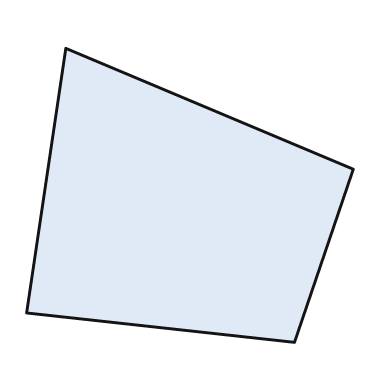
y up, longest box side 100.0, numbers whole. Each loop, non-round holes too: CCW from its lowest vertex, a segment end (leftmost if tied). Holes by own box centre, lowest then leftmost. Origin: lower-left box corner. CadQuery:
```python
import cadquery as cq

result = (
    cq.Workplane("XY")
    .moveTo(82.0, 0.0)
    .lineTo(100.0, 53.0)
    .lineTo(12.0, 90.0)
    .lineTo(0.0, 9.0)
    .close()
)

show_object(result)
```